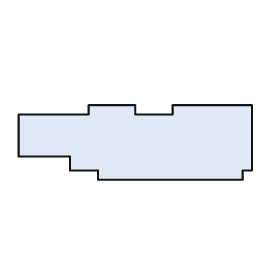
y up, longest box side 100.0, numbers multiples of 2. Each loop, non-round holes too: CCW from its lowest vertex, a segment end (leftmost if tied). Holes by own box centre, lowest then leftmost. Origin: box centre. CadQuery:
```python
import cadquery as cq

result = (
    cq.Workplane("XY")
    .moveTo(-16.0, -16.0)
    .lineTo(46.0, -16.0)
    .lineTo(46.0, -12.0)
    .lineTo(50.0, -12.0)
    .lineTo(50.0, 16.0)
    .lineTo(16.0, 16.0)
    .lineTo(16.0, 12.0)
    .lineTo(0.0, 12.0)
    .lineTo(0.0, 16.0)
    .lineTo(-20.0, 16.0)
    .lineTo(-20.0, 12.0)
    .lineTo(-50.0, 12.0)
    .lineTo(-50.0, -6.0)
    .lineTo(-28.0, -6.0)
    .lineTo(-28.0, -12.0)
    .lineTo(-16.0, -12.0)
    .close()
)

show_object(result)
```